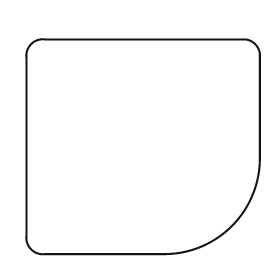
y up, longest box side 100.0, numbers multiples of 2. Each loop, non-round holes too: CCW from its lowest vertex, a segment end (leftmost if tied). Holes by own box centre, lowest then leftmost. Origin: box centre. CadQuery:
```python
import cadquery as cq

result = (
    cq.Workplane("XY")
    .moveTo(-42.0, -46.0)
    .lineTo(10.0, -46.0)
    .threePointArc((38.0, -34.0), (50.0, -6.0))
    .lineTo(50.0, 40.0)
    .threePointArc((48.0, 44.0), (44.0, 46.0))
    .lineTo(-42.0, 46.0)
    .threePointArc((-48.0, 44.0), (-50.0, 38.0))
    .lineTo(-50.0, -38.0)
    .threePointArc((-48.0, -44.0), (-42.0, -46.0))
    .close()
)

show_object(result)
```